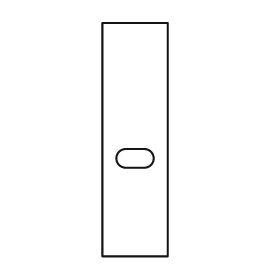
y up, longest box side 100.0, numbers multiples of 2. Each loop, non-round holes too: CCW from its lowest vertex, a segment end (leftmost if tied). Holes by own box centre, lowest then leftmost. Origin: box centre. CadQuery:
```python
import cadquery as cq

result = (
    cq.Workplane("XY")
    .moveTo(-14.0, -50.0)
    .lineTo(14.0, -50.0)
    .lineTo(14.0, 50.0)
    .lineTo(-14.0, 50.0)
    .close()
    .moveTo(-4.0, -12.0)
    .lineTo(4.0, -12.0)
    .threePointArc((8.0, -8.0), (4.0, -4.0))
    .lineTo(-4.0, -4.0)
    .threePointArc((-8.0, -8.0), (-4.0, -12.0))
    .close()
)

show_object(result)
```